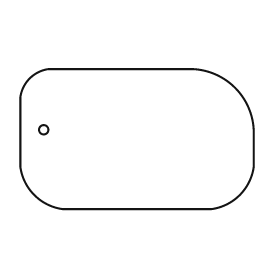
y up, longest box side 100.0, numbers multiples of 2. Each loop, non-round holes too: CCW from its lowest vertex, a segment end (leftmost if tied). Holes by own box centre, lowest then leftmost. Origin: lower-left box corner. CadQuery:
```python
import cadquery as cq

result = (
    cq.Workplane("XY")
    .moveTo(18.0, 0.0)
    .lineTo(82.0, 0.0)
    .threePointArc((94.0, 6.0), (100.0, 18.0))
    .lineTo(100.0, 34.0)
    .threePointArc((92.0, 52.0), (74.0, 60.0))
    .lineTo(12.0, 60.0)
    .threePointArc((4.0, 56.0), (0.0, 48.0))
    .lineTo(0.0, 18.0)
    .threePointArc((6.0, 6.0), (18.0, 0.0))
    .close()
    .moveTo(10.0, 34.0)
    .circle(2.0)
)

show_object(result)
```